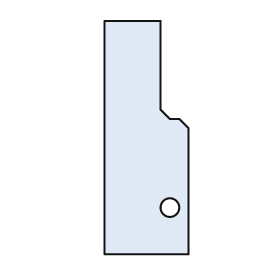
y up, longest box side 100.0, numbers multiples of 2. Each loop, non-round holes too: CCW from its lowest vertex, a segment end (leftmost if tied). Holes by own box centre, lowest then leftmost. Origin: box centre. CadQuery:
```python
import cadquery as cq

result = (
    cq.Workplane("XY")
    .moveTo(-18.0, -50.0)
    .lineTo(18.0, -50.0)
    .lineTo(18.0, 4.0)
    .lineTo(14.0, 8.0)
    .lineTo(10.0, 8.0)
    .lineTo(6.0, 12.0)
    .lineTo(6.0, 50.0)
    .lineTo(-18.0, 50.0)
    .close()
    .moveTo(10.0, -30.0)
    .circle(4.0)
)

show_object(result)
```